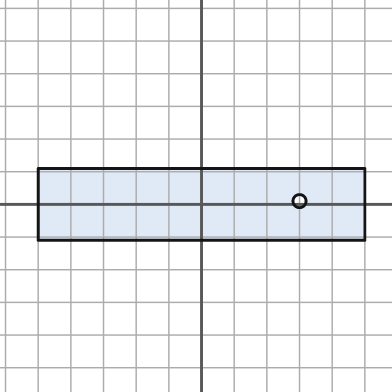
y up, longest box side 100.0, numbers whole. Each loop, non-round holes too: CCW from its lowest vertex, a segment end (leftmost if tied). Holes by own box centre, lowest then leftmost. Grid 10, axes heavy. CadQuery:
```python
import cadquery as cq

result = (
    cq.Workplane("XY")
    .moveTo(-50.0, -11.0)
    .lineTo(50.0, -11.0)
    .lineTo(50.0, 11.0)
    .lineTo(-50.0, 11.0)
    .close()
    .moveTo(30.0, 1.0)
    .circle(2.0)
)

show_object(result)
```